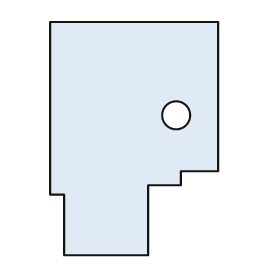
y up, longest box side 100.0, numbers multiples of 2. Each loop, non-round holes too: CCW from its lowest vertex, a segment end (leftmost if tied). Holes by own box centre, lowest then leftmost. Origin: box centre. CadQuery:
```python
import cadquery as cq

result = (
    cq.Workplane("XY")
    .moveTo(-30.0, -50.0)
    .lineTo(6.0, -50.0)
    .lineTo(6.0, -20.0)
    .lineTo(20.0, -20.0)
    .lineTo(20.0, -14.0)
    .lineTo(36.0, -14.0)
    .lineTo(36.0, 50.0)
    .lineTo(-36.0, 50.0)
    .lineTo(-36.0, -24.0)
    .lineTo(-30.0, -24.0)
    .close()
    .moveTo(18.0, 10.0)
    .circle(6.0)
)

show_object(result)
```